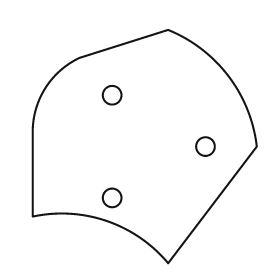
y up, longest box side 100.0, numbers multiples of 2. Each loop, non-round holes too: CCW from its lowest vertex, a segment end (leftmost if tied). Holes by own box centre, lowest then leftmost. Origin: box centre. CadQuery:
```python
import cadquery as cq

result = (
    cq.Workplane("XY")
    .moveTo(10.0, -50.0)
    .lineTo(48.0, 0.0)
    .threePointArc((36.0, 30.0), (10.0, 50.0))
    .lineTo(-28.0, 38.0)
    .threePointArc((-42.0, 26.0), (-48.0, 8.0))
    .lineTo(-48.0, -30.0)
    .threePointArc((-16.0, -32.0), (10.0, -50.0))
    .close()
    .moveTo(-14.0, -22.0)
    .circle(4.0)
    .moveTo(26.0, 0.0)
    .circle(4.0)
    .moveTo(-14.0, 22.0)
    .circle(4.0)
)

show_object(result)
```